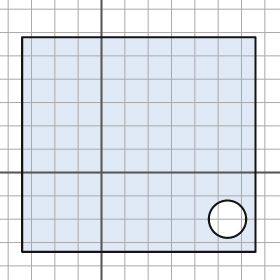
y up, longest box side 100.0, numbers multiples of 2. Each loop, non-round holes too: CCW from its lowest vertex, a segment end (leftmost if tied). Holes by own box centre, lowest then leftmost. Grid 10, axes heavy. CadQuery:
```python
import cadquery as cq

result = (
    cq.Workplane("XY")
    .moveTo(-34.0, -34.0)
    .lineTo(66.0, -34.0)
    .lineTo(66.0, 58.0)
    .lineTo(-34.0, 58.0)
    .close()
    .moveTo(54.0, -20.0)
    .circle(8.0)
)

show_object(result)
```